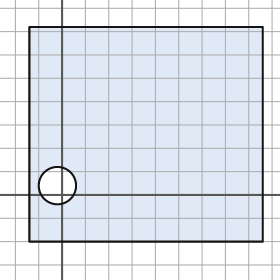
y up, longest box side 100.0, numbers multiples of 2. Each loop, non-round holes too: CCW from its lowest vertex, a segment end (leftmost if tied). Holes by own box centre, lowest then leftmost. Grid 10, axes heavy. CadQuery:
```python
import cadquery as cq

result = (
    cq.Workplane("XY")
    .moveTo(-14.0, -20.0)
    .lineTo(86.0, -20.0)
    .lineTo(86.0, 72.0)
    .lineTo(-14.0, 72.0)
    .close()
    .moveTo(-2.0, 4.0)
    .circle(8.0)
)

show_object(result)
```